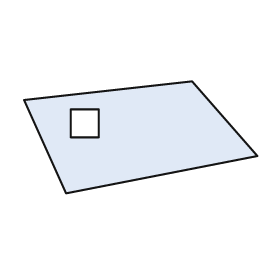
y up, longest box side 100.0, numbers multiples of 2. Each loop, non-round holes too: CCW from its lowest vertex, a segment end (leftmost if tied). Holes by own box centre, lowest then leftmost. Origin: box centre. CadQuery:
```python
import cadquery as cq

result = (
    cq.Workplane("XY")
    .moveTo(-32.0, -24.0)
    .lineTo(50.0, -8.0)
    .lineTo(22.0, 24.0)
    .lineTo(-50.0, 16.0)
    .close()
    .moveTo(-30.0, 0.0)
    .lineTo(-18.0, 0.0)
    .lineTo(-18.0, 12.0)
    .lineTo(-30.0, 12.0)
    .close()
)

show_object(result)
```